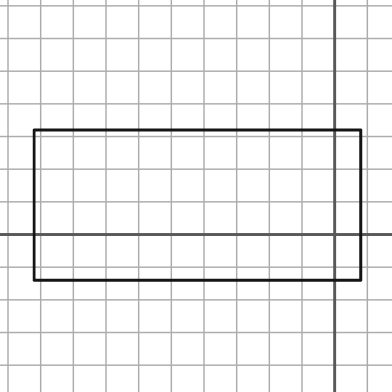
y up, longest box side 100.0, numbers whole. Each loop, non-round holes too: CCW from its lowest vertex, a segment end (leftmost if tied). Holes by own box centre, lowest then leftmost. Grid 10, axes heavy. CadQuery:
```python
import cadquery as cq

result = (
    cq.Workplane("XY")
    .moveTo(-92.0, -14.0)
    .lineTo(8.0, -14.0)
    .lineTo(8.0, 32.0)
    .lineTo(-92.0, 32.0)
    .close()
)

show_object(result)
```